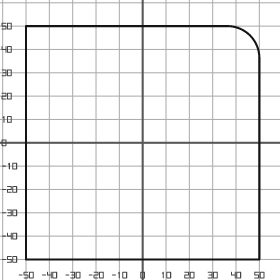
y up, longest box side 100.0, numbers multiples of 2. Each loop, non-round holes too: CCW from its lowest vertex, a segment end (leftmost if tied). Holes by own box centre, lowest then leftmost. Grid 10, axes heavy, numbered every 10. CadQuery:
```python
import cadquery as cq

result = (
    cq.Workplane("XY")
    .moveTo(-50.0, -50.0)
    .lineTo(50.0, -50.0)
    .lineTo(50.0, 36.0)
    .threePointArc((46.0, 46.0), (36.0, 50.0))
    .lineTo(-50.0, 50.0)
    .close()
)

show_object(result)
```